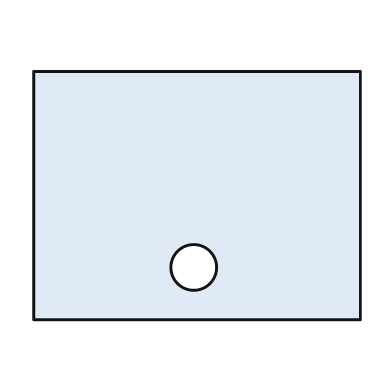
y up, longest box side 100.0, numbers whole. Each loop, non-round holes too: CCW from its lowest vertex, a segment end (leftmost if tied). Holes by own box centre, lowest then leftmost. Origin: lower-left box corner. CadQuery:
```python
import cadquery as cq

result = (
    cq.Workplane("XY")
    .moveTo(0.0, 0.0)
    .lineTo(100.0, 0.0)
    .lineTo(100.0, 76.0)
    .lineTo(0.0, 76.0)
    .close()
    .moveTo(49.0, 16.0)
    .circle(7.0)
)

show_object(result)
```